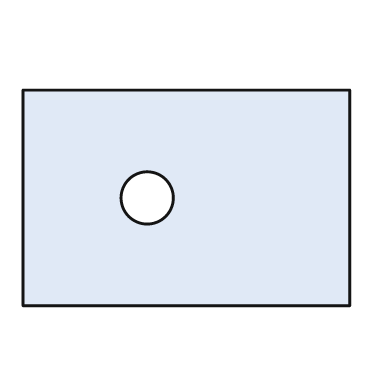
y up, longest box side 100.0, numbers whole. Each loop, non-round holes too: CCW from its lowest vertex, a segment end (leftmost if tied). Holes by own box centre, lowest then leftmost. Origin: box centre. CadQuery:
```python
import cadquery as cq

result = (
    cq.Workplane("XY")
    .moveTo(-50.0, -33.0)
    .lineTo(50.0, -33.0)
    .lineTo(50.0, 33.0)
    .lineTo(-50.0, 33.0)
    .close()
    .moveTo(-12.0, 0.0)
    .circle(8.0)
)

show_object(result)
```